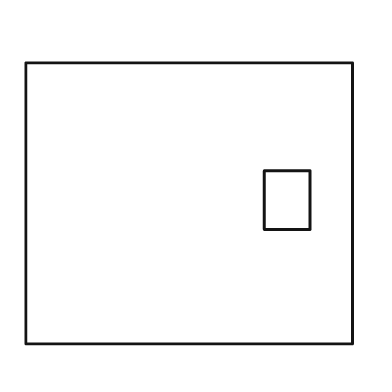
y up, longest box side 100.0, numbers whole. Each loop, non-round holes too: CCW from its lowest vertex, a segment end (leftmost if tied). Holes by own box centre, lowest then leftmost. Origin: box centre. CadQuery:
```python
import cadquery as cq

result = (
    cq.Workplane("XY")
    .moveTo(-50.0, -43.0)
    .lineTo(50.0, -43.0)
    .lineTo(50.0, 43.0)
    .lineTo(-50.0, 43.0)
    .close()
    .moveTo(23.0, -8.0)
    .lineTo(37.0, -8.0)
    .lineTo(37.0, 10.0)
    .lineTo(23.0, 10.0)
    .close()
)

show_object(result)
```